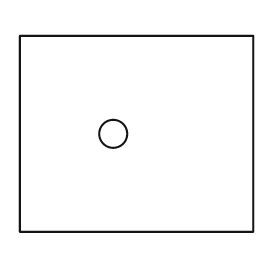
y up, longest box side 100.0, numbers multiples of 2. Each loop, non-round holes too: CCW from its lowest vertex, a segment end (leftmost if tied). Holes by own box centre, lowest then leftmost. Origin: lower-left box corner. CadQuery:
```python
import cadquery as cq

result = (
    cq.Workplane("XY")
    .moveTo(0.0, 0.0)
    .lineTo(100.0, 0.0)
    .lineTo(100.0, 84.0)
    .lineTo(0.0, 84.0)
    .close()
    .moveTo(40.0, 42.0)
    .circle(6.0)
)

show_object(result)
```